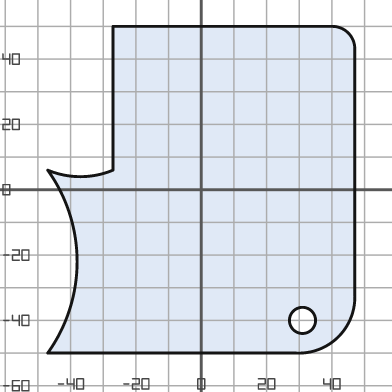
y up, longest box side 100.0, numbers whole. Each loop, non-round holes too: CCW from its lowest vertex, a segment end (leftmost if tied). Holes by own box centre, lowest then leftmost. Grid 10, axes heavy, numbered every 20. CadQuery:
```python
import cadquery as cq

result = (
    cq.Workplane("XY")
    .moveTo(-47.0, -50.0)
    .lineTo(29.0, -50.0)
    .threePointArc((42.0, -45.0), (47.0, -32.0))
    .lineTo(47.0, 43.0)
    .threePointArc((45.0, 48.0), (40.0, 50.0))
    .lineTo(-27.0, 50.0)
    .lineTo(-27.0, 6.0)
    .threePointArc((-37.0, 4.0), (-47.0, 6.0))
    .threePointArc((-38.0, -22.0), (-47.0, -50.0))
    .close()
    .moveTo(31.0, -40.0)
    .circle(4.0)
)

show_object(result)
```